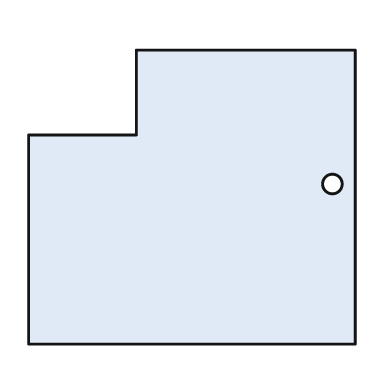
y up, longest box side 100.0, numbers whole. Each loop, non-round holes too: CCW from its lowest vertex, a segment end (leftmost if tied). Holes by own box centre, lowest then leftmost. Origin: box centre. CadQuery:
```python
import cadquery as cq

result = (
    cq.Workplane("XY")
    .moveTo(-50.0, -45.0)
    .lineTo(50.0, -45.0)
    .lineTo(50.0, 45.0)
    .lineTo(-17.0, 45.0)
    .lineTo(-17.0, 19.0)
    .lineTo(-50.0, 19.0)
    .close()
    .moveTo(43.0, 4.0)
    .circle(3.0)
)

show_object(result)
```